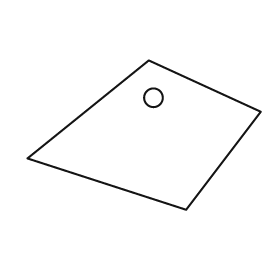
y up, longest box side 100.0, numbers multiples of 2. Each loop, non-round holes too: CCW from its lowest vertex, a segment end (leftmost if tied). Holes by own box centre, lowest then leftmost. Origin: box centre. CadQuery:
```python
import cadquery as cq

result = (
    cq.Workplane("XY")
    .moveTo(18.0, -32.0)
    .lineTo(50.0, 10.0)
    .lineTo(2.0, 32.0)
    .lineTo(-50.0, -10.0)
    .close()
    .moveTo(4.0, 16.0)
    .circle(4.0)
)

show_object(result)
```